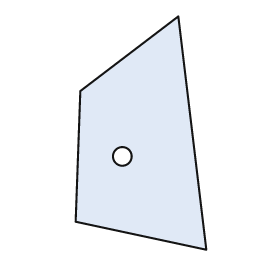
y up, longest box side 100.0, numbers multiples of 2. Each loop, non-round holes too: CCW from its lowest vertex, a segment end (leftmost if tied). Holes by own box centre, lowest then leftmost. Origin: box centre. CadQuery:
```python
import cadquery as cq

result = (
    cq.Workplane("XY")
    .moveTo(28.0, -50.0)
    .lineTo(16.0, 50.0)
    .lineTo(-26.0, 18.0)
    .lineTo(-28.0, -38.0)
    .close()
    .moveTo(-8.0, -10.0)
    .circle(4.0)
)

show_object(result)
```